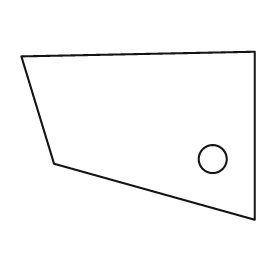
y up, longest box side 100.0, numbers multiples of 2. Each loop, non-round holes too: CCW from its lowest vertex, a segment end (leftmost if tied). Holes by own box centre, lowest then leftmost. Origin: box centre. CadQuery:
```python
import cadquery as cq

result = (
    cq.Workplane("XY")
    .moveTo(50.0, -36.0)
    .lineTo(50.0, 36.0)
    .lineTo(-50.0, 34.0)
    .lineTo(-36.0, -12.0)
    .close()
    .moveTo(32.0, -10.0)
    .circle(6.0)
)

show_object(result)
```